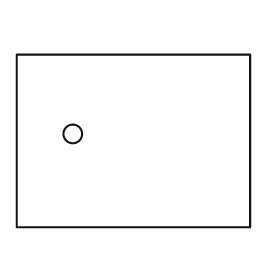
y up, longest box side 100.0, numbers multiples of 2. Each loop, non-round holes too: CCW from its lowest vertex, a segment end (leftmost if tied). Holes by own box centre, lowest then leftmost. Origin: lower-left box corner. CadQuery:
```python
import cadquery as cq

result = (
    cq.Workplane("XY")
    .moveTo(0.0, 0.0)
    .lineTo(100.0, 0.0)
    .lineTo(100.0, 74.0)
    .lineTo(0.0, 74.0)
    .close()
    .moveTo(24.0, 40.0)
    .circle(4.0)
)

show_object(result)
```